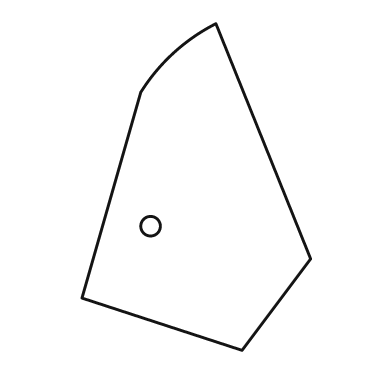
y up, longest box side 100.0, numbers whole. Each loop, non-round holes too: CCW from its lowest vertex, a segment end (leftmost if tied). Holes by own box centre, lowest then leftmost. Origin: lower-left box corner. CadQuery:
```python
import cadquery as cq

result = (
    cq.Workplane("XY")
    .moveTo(49.0, 0.0)
    .lineTo(70.0, 28.0)
    .lineTo(41.0, 100.0)
    .threePointArc((28.0, 91.0), (18.0, 79.0))
    .lineTo(0.0, 16.0)
    .close()
    .moveTo(21.0, 38.0)
    .circle(3.0)
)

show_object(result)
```